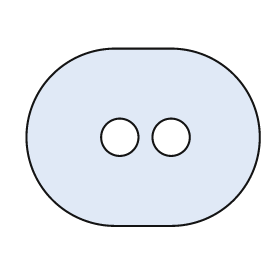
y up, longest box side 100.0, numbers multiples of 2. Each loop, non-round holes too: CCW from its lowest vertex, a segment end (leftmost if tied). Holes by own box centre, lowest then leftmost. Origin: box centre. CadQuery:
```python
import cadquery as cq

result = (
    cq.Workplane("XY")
    .moveTo(-12.0, -38.0)
    .lineTo(12.0, -38.0)
    .threePointArc((50.0, 0.0), (12.0, 38.0))
    .lineTo(-12.0, 38.0)
    .threePointArc((-50.0, 0.0), (-12.0, -38.0))
    .close()
    .moveTo(-10.0, 0.0)
    .circle(8.0)
    .moveTo(12.0, 0.0)
    .circle(8.0)
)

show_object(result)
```